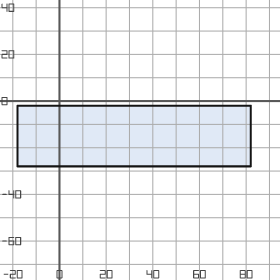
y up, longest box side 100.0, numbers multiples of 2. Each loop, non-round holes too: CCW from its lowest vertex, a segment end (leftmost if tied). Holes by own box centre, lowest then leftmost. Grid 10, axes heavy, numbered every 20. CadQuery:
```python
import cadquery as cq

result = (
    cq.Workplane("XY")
    .moveTo(-18.0, -28.0)
    .lineTo(82.0, -28.0)
    .lineTo(82.0, -2.0)
    .lineTo(-18.0, -2.0)
    .close()
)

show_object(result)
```